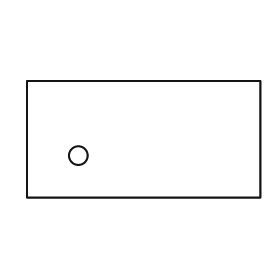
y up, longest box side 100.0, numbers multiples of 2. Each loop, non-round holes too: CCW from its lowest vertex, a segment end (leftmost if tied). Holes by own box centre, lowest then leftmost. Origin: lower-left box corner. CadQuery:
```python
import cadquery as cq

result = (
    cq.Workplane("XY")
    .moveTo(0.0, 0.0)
    .lineTo(100.0, 0.0)
    .lineTo(100.0, 50.0)
    .lineTo(0.0, 50.0)
    .close()
    .moveTo(22.0, 18.0)
    .circle(4.0)
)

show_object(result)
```